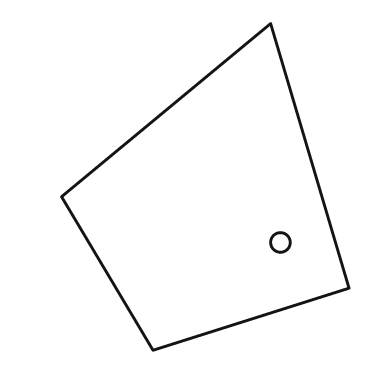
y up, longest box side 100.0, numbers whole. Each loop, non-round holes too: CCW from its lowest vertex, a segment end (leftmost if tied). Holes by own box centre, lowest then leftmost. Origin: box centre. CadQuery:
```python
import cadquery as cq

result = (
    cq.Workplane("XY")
    .moveTo(-16.0, -50.0)
    .lineTo(44.0, -31.0)
    .lineTo(20.0, 50.0)
    .lineTo(-44.0, -3.0)
    .close()
    .moveTo(23.0, -17.0)
    .circle(3.0)
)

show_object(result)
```